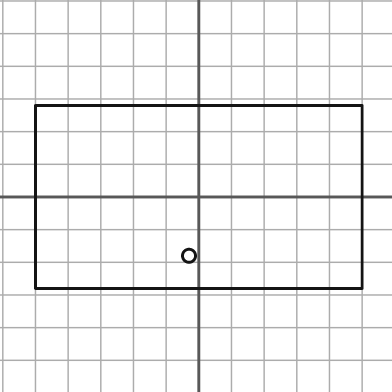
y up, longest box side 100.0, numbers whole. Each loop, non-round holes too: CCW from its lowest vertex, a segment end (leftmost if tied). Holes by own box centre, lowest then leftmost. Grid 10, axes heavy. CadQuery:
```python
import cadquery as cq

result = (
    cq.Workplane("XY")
    .moveTo(-50.0, -28.0)
    .lineTo(50.0, -28.0)
    .lineTo(50.0, 28.0)
    .lineTo(-50.0, 28.0)
    .close()
    .moveTo(-3.0, -18.0)
    .circle(2.0)
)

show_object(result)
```